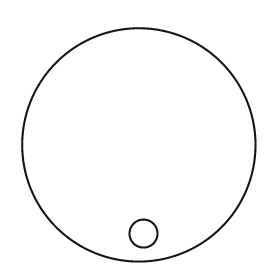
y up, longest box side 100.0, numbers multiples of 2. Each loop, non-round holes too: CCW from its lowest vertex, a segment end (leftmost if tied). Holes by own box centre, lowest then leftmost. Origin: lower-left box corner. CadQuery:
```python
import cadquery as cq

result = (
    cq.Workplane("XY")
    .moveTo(50.0, 50.0)
    .circle(50.0)
    .moveTo(52.0, 12.0)
    .circle(6.0)
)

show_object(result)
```